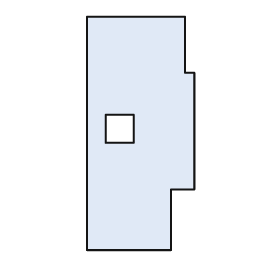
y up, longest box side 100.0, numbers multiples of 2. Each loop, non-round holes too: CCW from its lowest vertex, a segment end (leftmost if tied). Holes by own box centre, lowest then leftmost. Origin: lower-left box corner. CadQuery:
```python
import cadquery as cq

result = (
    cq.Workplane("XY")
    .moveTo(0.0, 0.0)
    .lineTo(36.0, 0.0)
    .lineTo(36.0, 26.0)
    .lineTo(46.0, 26.0)
    .lineTo(46.0, 76.0)
    .lineTo(42.0, 76.0)
    .lineTo(42.0, 100.0)
    .lineTo(0.0, 100.0)
    .close()
    .moveTo(8.0, 46.0)
    .lineTo(20.0, 46.0)
    .lineTo(20.0, 58.0)
    .lineTo(8.0, 58.0)
    .close()
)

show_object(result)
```